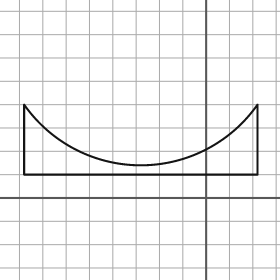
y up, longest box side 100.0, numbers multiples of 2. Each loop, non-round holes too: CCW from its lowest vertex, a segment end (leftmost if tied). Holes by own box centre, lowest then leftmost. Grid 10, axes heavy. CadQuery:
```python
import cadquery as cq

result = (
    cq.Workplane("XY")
    .moveTo(-78.0, 10.0)
    .lineTo(22.0, 10.0)
    .lineTo(22.0, 40.0)
    .threePointArc((-28.0, 14.0), (-78.0, 40.0))
    .close()
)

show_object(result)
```